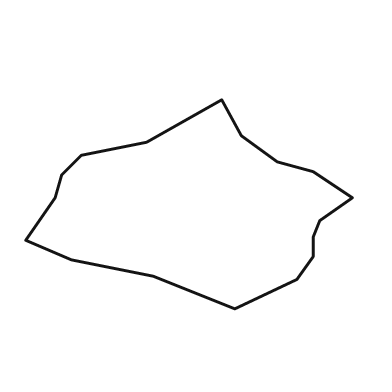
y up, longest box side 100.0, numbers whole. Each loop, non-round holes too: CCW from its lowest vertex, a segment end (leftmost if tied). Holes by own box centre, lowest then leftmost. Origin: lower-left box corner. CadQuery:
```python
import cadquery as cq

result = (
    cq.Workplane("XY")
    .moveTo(64.0, 0.0)
    .lineTo(83.0, 9.0)
    .lineTo(88.0, 16.0)
    .lineTo(88.0, 22.0)
    .lineTo(90.0, 27.0)
    .lineTo(100.0, 34.0)
    .lineTo(88.0, 42.0)
    .lineTo(77.0, 45.0)
    .lineTo(66.0, 53.0)
    .lineTo(60.0, 64.0)
    .lineTo(37.0, 51.0)
    .lineTo(17.0, 47.0)
    .lineTo(11.0, 41.0)
    .lineTo(9.0, 34.0)
    .lineTo(0.0, 21.0)
    .lineTo(14.0, 15.0)
    .lineTo(39.0, 10.0)
    .close()
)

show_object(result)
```